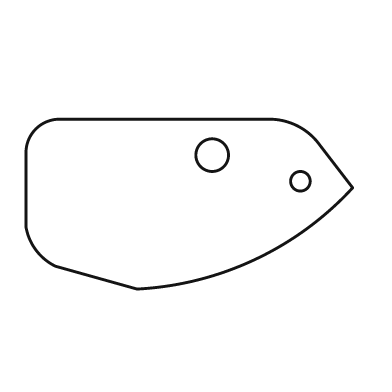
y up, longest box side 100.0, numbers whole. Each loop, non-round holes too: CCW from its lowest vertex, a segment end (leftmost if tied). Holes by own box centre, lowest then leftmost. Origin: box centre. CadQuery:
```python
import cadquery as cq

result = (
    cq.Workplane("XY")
    .moveTo(-16.0, -26.0)
    .threePointArc((20.0, -17.0), (50.0, 5.0))
    .lineTo(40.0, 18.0)
    .threePointArc((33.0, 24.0), (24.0, 26.0))
    .lineTo(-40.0, 26.0)
    .threePointArc((-47.0, 23.0), (-50.0, 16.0))
    .lineTo(-50.0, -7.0)
    .threePointArc((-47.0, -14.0), (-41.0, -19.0))
    .close()
    .moveTo(34.0, 7.0)
    .circle(3.0)
    .moveTo(7.0, 15.0)
    .circle(5.0)
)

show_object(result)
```